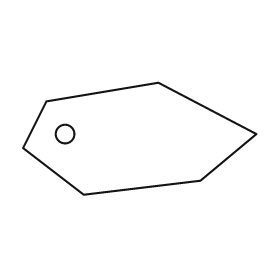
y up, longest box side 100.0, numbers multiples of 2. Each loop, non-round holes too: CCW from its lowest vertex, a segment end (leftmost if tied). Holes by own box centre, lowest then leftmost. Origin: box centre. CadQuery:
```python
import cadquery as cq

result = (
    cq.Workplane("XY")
    .moveTo(-24.0, -24.0)
    .lineTo(26.0, -18.0)
    .lineTo(50.0, 2.0)
    .lineTo(8.0, 24.0)
    .lineTo(-40.0, 16.0)
    .lineTo(-50.0, -4.0)
    .close()
    .moveTo(-32.0, 2.0)
    .circle(4.0)
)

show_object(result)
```